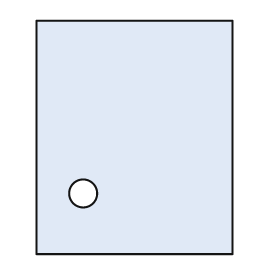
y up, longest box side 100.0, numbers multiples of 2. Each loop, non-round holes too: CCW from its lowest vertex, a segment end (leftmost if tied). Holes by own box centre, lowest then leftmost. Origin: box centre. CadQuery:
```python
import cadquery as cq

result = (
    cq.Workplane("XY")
    .moveTo(-42.0, -50.0)
    .lineTo(42.0, -50.0)
    .lineTo(42.0, 50.0)
    .lineTo(-42.0, 50.0)
    .close()
    .moveTo(-22.0, -24.0)
    .circle(6.0)
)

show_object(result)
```